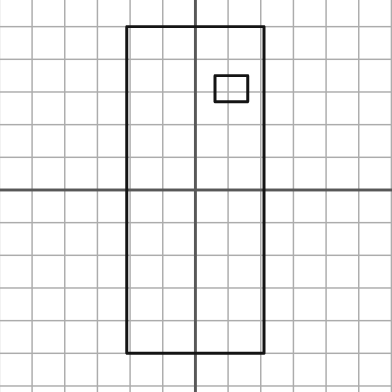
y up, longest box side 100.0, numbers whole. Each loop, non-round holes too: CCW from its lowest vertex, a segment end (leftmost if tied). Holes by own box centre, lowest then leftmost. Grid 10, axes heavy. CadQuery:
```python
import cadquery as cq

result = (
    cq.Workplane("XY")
    .moveTo(-21.0, -50.0)
    .lineTo(21.0, -50.0)
    .lineTo(21.0, 50.0)
    .lineTo(-21.0, 50.0)
    .close()
    .moveTo(6.0, 27.0)
    .lineTo(16.0, 27.0)
    .lineTo(16.0, 35.0)
    .lineTo(6.0, 35.0)
    .close()
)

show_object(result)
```